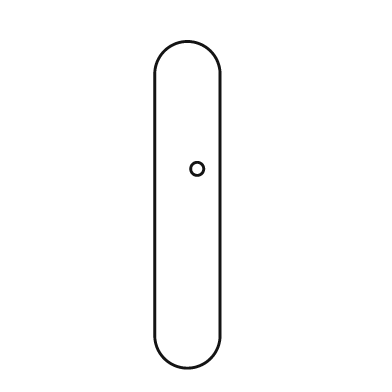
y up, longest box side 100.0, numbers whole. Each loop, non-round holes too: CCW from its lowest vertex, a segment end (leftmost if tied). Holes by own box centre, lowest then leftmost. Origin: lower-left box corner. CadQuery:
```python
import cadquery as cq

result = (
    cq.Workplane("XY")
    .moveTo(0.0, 10.0)
    .threePointArc((10.0, 0.0), (20.0, 10.0))
    .lineTo(20.0, 90.0)
    .threePointArc((10.0, 100.0), (0.0, 90.0))
    .close()
    .moveTo(13.0, 61.0)
    .circle(2.0)
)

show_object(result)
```